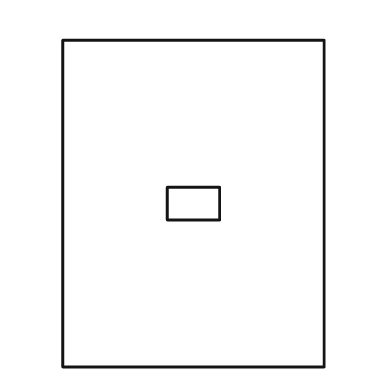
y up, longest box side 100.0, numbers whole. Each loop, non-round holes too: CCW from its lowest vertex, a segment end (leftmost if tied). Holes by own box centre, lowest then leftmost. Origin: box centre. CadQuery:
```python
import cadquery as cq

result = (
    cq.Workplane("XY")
    .moveTo(-40.0, -50.0)
    .lineTo(40.0, -50.0)
    .lineTo(40.0, 50.0)
    .lineTo(-40.0, 50.0)
    .close()
    .moveTo(-8.0, -5.0)
    .lineTo(8.0, -5.0)
    .lineTo(8.0, 5.0)
    .lineTo(-8.0, 5.0)
    .close()
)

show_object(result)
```